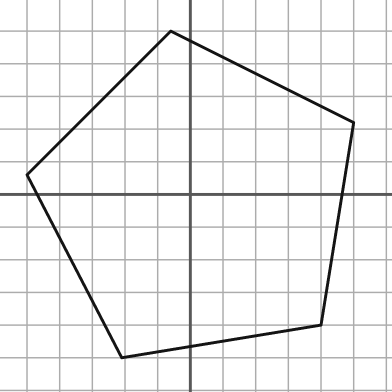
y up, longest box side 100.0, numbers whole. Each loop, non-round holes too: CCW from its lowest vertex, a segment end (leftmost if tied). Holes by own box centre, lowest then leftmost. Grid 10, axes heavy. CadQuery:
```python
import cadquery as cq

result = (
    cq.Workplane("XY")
    .moveTo(-21.0, -50.0)
    .lineTo(40.0, -40.0)
    .lineTo(50.0, 22.0)
    .lineTo(-6.0, 50.0)
    .lineTo(-50.0, 6.0)
    .close()
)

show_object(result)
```